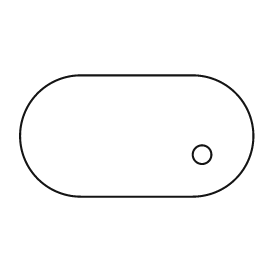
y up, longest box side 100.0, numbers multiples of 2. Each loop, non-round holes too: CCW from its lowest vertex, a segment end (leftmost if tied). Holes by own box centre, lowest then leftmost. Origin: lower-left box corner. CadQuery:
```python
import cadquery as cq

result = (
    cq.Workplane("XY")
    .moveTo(26.0, 0.0)
    .lineTo(74.0, 0.0)
    .threePointArc((100.0, 26.0), (74.0, 52.0))
    .lineTo(26.0, 52.0)
    .threePointArc((0.0, 26.0), (26.0, 0.0))
    .close()
    .moveTo(78.0, 18.0)
    .circle(4.0)
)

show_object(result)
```